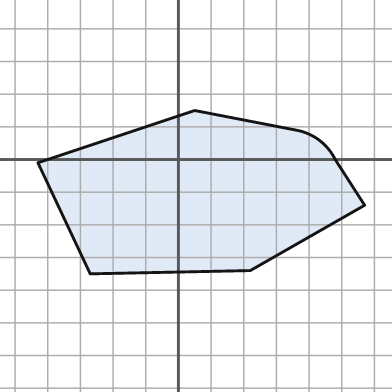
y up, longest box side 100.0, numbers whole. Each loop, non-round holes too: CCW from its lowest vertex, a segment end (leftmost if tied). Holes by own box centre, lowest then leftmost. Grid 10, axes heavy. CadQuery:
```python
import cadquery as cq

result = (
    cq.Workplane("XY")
    .moveTo(-27.0, -35.0)
    .lineTo(22.0, -34.0)
    .lineTo(57.0, -14.0)
    .lineTo(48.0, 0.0)
    .threePointArc((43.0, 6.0), (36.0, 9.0))
    .lineTo(5.0, 15.0)
    .lineTo(-43.0, -1.0)
    .close()
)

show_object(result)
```